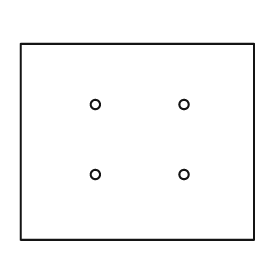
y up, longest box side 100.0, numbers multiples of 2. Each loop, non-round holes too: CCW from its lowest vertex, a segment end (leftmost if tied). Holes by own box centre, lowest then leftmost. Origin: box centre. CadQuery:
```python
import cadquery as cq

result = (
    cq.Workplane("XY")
    .moveTo(-50.0, -42.0)
    .lineTo(50.0, -42.0)
    .lineTo(50.0, 42.0)
    .lineTo(-50.0, 42.0)
    .close()
    .moveTo(-18.0, -14.0)
    .circle(2.0)
    .moveTo(20.0, -14.0)
    .circle(2.0)
    .moveTo(-18.0, 16.0)
    .circle(2.0)
    .moveTo(20.0, 16.0)
    .circle(2.0)
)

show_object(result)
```